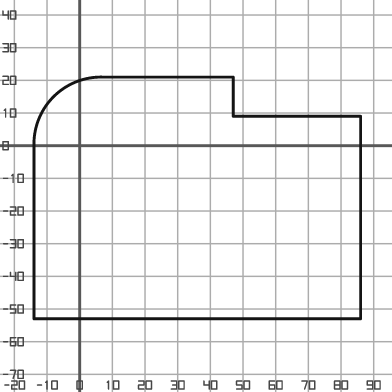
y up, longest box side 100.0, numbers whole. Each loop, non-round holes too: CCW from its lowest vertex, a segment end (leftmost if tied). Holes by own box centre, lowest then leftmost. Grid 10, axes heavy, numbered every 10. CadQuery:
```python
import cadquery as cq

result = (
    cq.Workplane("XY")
    .moveTo(-14.0, -53.0)
    .lineTo(86.0, -53.0)
    .lineTo(86.0, 9.0)
    .lineTo(47.0, 9.0)
    .lineTo(47.0, 21.0)
    .lineTo(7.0, 21.0)
    .threePointArc((-8.0, 15.0), (-14.0, 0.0))
    .close()
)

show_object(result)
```